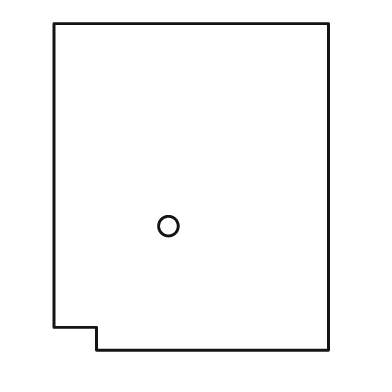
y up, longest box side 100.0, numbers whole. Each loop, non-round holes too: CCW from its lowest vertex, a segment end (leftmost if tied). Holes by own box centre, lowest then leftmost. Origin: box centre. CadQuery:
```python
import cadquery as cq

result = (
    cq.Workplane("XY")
    .moveTo(-29.0, -50.0)
    .lineTo(42.0, -50.0)
    .lineTo(42.0, 50.0)
    .lineTo(-42.0, 50.0)
    .lineTo(-42.0, -43.0)
    .lineTo(-29.0, -43.0)
    .close()
    .moveTo(-7.0, -12.0)
    .circle(3.0)
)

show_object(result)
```